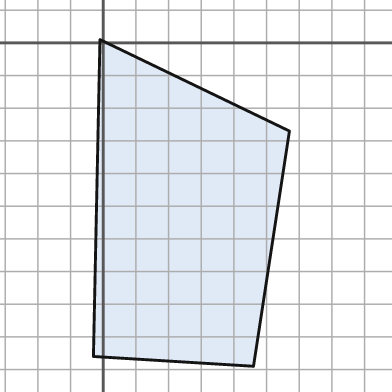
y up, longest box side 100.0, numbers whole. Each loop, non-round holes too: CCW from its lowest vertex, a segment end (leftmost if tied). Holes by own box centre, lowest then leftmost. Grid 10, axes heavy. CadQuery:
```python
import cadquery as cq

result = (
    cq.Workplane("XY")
    .moveTo(46.0, -99.0)
    .lineTo(57.0, -27.0)
    .lineTo(-1.0, 1.0)
    .lineTo(-3.0, -96.0)
    .close()
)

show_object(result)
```